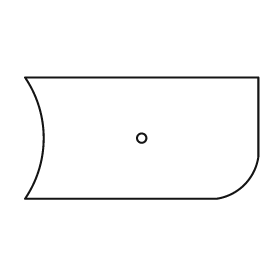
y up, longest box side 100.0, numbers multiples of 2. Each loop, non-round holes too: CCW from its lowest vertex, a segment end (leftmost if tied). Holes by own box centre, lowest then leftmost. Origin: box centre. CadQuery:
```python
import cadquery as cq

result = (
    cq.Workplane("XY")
    .moveTo(-50.0, -26.0)
    .lineTo(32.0, -26.0)
    .threePointArc((44.0, -20.0), (50.0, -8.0))
    .lineTo(50.0, 26.0)
    .lineTo(-50.0, 26.0)
    .threePointArc((-42.0, 0.0), (-50.0, -26.0))
    .close()
    .moveTo(0.0, 0.0)
    .circle(2.0)
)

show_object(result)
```